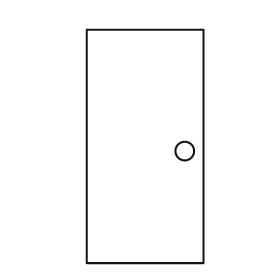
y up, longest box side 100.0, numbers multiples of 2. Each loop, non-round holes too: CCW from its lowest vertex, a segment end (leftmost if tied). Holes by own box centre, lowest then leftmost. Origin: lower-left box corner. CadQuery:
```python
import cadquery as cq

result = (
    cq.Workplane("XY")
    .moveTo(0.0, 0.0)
    .lineTo(50.0, 0.0)
    .lineTo(50.0, 100.0)
    .lineTo(0.0, 100.0)
    .close()
    .moveTo(42.0, 48.0)
    .circle(4.0)
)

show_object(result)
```